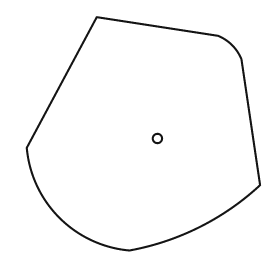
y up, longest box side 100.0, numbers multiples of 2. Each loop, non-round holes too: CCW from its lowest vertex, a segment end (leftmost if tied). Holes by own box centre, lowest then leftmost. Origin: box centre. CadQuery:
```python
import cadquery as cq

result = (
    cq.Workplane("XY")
    .moveTo(-6.0, -50.0)
    .threePointArc((24.0, -40.0), (50.0, -22.0))
    .lineTo(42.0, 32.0)
    .threePointArc((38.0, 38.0), (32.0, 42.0))
    .lineTo(-20.0, 50.0)
    .lineTo(-50.0, -6.0)
    .threePointArc((-36.0, -36.0), (-6.0, -50.0))
    .close()
    .moveTo(6.0, -2.0)
    .circle(2.0)
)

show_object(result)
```